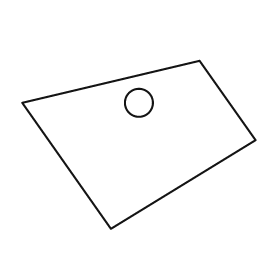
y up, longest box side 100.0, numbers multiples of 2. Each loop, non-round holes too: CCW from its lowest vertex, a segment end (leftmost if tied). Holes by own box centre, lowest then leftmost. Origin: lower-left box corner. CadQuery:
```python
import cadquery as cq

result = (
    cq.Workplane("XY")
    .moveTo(38.0, 0.0)
    .lineTo(100.0, 38.0)
    .lineTo(76.0, 72.0)
    .lineTo(0.0, 54.0)
    .close()
    .moveTo(50.0, 54.0)
    .circle(6.0)
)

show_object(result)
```